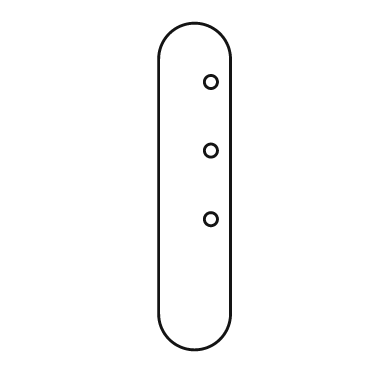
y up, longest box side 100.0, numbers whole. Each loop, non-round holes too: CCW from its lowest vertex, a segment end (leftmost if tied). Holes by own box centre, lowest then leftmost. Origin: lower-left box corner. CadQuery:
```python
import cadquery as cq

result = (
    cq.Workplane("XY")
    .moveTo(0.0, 11.0)
    .threePointArc((11.0, 0.0), (22.0, 11.0))
    .lineTo(22.0, 89.0)
    .threePointArc((11.0, 100.0), (0.0, 89.0))
    .close()
    .moveTo(16.0, 40.0)
    .circle(2.0)
    .moveTo(16.0, 61.0)
    .circle(2.0)
    .moveTo(16.0, 82.0)
    .circle(2.0)
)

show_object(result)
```